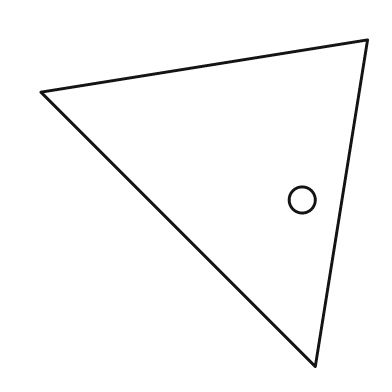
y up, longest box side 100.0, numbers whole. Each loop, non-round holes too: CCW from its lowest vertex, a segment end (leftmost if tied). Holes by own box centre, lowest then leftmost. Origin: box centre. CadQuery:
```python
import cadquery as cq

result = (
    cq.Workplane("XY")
    .moveTo(34.0, -50.0)
    .lineTo(50.0, 50.0)
    .lineTo(-50.0, 34.0)
    .close()
    .moveTo(30.0, 1.0)
    .circle(4.0)
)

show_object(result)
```